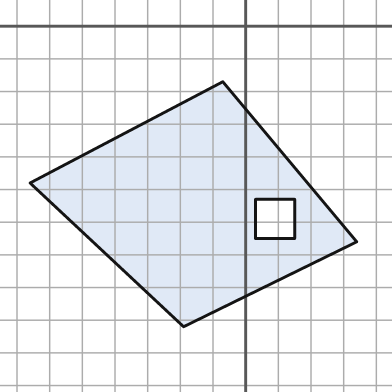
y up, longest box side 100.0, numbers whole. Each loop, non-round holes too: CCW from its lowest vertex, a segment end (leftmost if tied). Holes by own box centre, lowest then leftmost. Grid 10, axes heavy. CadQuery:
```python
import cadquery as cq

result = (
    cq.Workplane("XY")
    .moveTo(-19.0, -92.0)
    .lineTo(34.0, -66.0)
    .lineTo(-7.0, -17.0)
    .lineTo(-66.0, -48.0)
    .close()
    .moveTo(3.0, -65.0)
    .lineTo(15.0, -65.0)
    .lineTo(15.0, -53.0)
    .lineTo(3.0, -53.0)
    .close()
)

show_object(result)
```